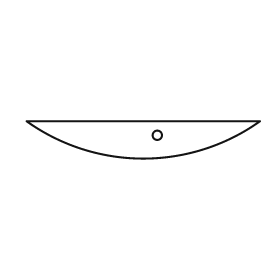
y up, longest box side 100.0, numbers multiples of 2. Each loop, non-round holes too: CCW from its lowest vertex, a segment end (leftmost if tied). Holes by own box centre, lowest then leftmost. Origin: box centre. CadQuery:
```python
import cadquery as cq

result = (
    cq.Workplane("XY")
    .moveTo(-50.0, 8.0)
    .threePointArc((0.0, -8.0), (50.0, 8.0))
    .close()
    .moveTo(6.0, 2.0)
    .circle(2.0)
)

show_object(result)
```